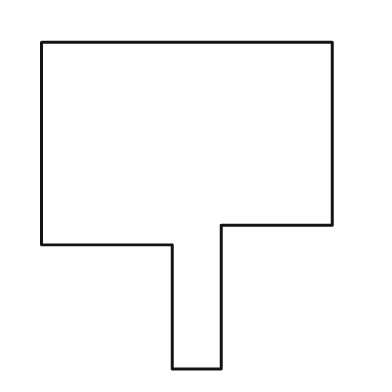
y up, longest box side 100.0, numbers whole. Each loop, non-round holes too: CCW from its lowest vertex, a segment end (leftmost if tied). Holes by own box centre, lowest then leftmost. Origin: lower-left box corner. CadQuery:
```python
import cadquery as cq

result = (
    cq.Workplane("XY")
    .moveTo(40.0, 0.0)
    .lineTo(55.0, 0.0)
    .lineTo(55.0, 44.0)
    .lineTo(89.0, 44.0)
    .lineTo(89.0, 100.0)
    .lineTo(0.0, 100.0)
    .lineTo(0.0, 38.0)
    .lineTo(40.0, 38.0)
    .close()
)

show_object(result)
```